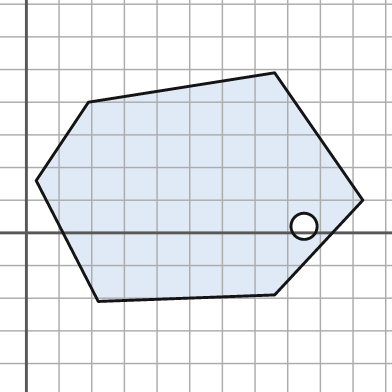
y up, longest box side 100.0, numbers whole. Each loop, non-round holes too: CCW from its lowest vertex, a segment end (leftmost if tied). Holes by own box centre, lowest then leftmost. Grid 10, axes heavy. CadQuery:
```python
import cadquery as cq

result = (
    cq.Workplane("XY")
    .moveTo(22.0, -21.0)
    .lineTo(76.0, -19.0)
    .lineTo(103.0, 10.0)
    .lineTo(76.0, 49.0)
    .lineTo(19.0, 40.0)
    .lineTo(3.0, 16.0)
    .close()
    .moveTo(85.0, 2.0)
    .circle(4.0)
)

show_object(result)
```